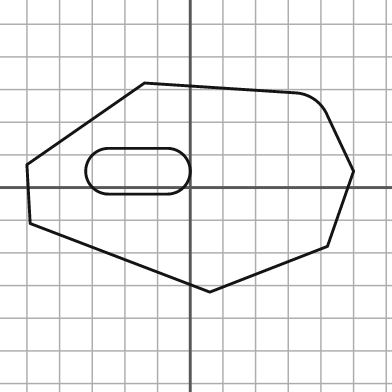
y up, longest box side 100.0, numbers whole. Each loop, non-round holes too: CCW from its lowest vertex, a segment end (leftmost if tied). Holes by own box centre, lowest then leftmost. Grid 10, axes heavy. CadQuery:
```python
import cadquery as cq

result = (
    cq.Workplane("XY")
    .moveTo(6.0, -32.0)
    .lineTo(42.0, -18.0)
    .lineTo(50.0, 5.0)
    .lineTo(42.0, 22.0)
    .threePointArc((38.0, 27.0), (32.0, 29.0))
    .lineTo(-14.0, 32.0)
    .lineTo(-50.0, 7.0)
    .lineTo(-49.0, -11.0)
    .close()
    .moveTo(-25.0, -2.0)
    .lineTo(-7.0, -2.0)
    .threePointArc((0.0, 5.0), (-7.0, 12.0))
    .lineTo(-25.0, 12.0)
    .threePointArc((-32.0, 5.0), (-25.0, -2.0))
    .close()
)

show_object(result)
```